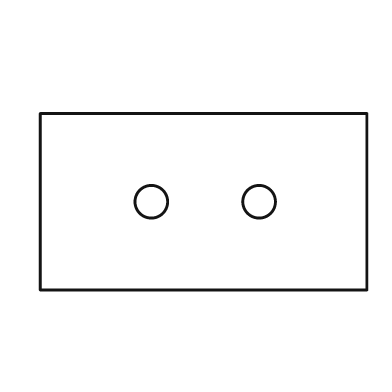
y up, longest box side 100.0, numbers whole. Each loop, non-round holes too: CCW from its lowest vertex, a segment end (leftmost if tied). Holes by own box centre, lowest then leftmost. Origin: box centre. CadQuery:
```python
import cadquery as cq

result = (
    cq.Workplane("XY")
    .moveTo(-50.0, -27.0)
    .lineTo(50.0, -27.0)
    .lineTo(50.0, 27.0)
    .lineTo(-50.0, 27.0)
    .close()
    .moveTo(-16.0, 0.0)
    .circle(5.0)
    .moveTo(17.0, 0.0)
    .circle(5.0)
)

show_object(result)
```